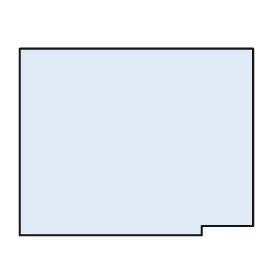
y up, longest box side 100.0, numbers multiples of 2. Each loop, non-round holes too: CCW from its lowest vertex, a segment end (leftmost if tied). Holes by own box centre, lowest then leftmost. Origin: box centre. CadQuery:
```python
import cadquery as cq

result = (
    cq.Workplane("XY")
    .moveTo(-50.0, -40.0)
    .lineTo(28.0, -40.0)
    .lineTo(28.0, -36.0)
    .lineTo(50.0, -36.0)
    .lineTo(50.0, 40.0)
    .lineTo(-50.0, 40.0)
    .close()
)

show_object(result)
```